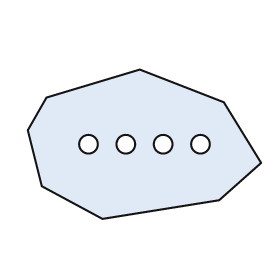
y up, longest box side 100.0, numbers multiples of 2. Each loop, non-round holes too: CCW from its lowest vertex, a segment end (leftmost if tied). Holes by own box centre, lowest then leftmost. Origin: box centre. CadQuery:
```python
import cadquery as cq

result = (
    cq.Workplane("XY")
    .moveTo(-18.0, -32.0)
    .lineTo(32.0, -24.0)
    .lineTo(50.0, -8.0)
    .lineTo(34.0, 18.0)
    .lineTo(-2.0, 32.0)
    .lineTo(-42.0, 20.0)
    .lineTo(-50.0, 6.0)
    .lineTo(-44.0, -18.0)
    .close()
    .moveTo(-24.0, 0.0)
    .circle(4.0)
    .moveTo(-8.0, 0.0)
    .circle(4.0)
    .moveTo(8.0, 0.0)
    .circle(4.0)
    .moveTo(24.0, 0.0)
    .circle(4.0)
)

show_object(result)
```